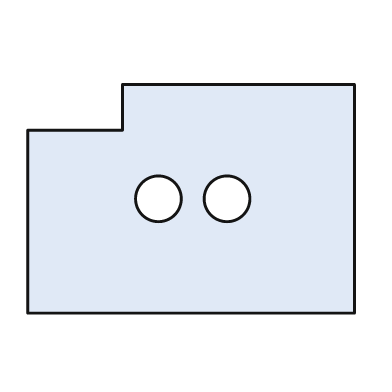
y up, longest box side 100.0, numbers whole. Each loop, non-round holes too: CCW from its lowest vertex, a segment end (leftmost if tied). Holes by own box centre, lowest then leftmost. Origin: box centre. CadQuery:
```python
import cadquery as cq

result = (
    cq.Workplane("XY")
    .moveTo(-50.0, -35.0)
    .lineTo(50.0, -35.0)
    .lineTo(50.0, 35.0)
    .lineTo(-21.0, 35.0)
    .lineTo(-21.0, 21.0)
    .lineTo(-50.0, 21.0)
    .close()
    .moveTo(-10.0, 0.0)
    .circle(7.0)
    .moveTo(11.0, 0.0)
    .circle(7.0)
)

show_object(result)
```